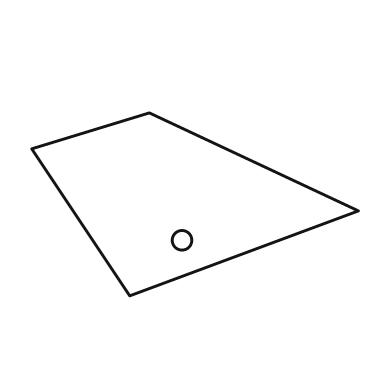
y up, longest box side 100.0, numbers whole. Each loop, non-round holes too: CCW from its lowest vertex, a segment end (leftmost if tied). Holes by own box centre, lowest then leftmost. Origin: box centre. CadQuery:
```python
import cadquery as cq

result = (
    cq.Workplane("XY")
    .moveTo(-20.0, -28.0)
    .lineTo(50.0, -2.0)
    .lineTo(-14.0, 28.0)
    .lineTo(-50.0, 17.0)
    .close()
    .moveTo(-4.0, -11.0)
    .circle(3.0)
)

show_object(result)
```